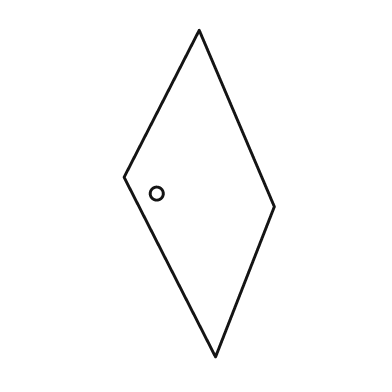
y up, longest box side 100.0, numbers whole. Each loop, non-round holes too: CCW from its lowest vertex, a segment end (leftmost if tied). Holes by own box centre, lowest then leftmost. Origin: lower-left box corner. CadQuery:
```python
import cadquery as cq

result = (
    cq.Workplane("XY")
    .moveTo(28.0, 0.0)
    .lineTo(46.0, 46.0)
    .lineTo(23.0, 100.0)
    .lineTo(0.0, 55.0)
    .close()
    .moveTo(10.0, 50.0)
    .circle(2.0)
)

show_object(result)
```